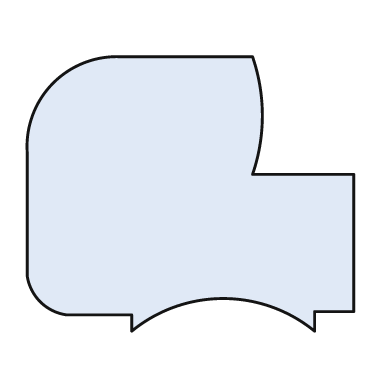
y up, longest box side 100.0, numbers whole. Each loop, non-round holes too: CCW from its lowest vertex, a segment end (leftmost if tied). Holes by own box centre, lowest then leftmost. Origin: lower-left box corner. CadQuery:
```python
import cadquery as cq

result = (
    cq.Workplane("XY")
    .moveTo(32.0, 0.0)
    .threePointArc((60.0, 10.0), (88.0, 0.0))
    .lineTo(88.0, 6.0)
    .lineTo(100.0, 6.0)
    .lineTo(100.0, 48.0)
    .lineTo(69.0, 48.0)
    .threePointArc((72.0, 66.0), (69.0, 84.0))
    .lineTo(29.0, 84.0)
    .threePointArc((8.0, 76.0), (0.0, 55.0))
    .lineTo(0.0, 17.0)
    .threePointArc((4.0, 9.0), (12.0, 5.0))
    .lineTo(32.0, 5.0)
    .close()
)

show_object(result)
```